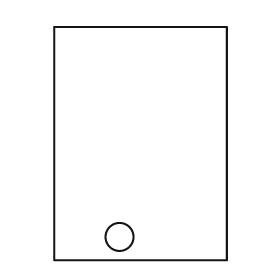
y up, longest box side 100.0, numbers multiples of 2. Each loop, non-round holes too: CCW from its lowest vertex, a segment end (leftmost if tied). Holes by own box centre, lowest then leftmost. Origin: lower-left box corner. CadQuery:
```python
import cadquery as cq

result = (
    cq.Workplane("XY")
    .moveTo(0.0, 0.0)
    .lineTo(74.0, 0.0)
    .lineTo(74.0, 100.0)
    .lineTo(0.0, 100.0)
    .close()
    .moveTo(28.0, 10.0)
    .circle(6.0)
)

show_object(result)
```